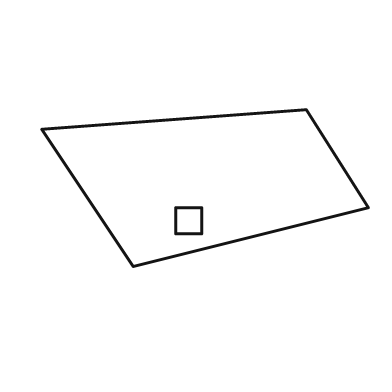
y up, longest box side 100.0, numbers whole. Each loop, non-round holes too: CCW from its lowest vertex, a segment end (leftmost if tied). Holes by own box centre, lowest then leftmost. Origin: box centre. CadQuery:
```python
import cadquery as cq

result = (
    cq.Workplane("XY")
    .moveTo(-22.0, -24.0)
    .lineTo(50.0, -6.0)
    .lineTo(31.0, 24.0)
    .lineTo(-50.0, 18.0)
    .close()
    .moveTo(-9.0, -14.0)
    .lineTo(-1.0, -14.0)
    .lineTo(-1.0, -6.0)
    .lineTo(-9.0, -6.0)
    .close()
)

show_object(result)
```